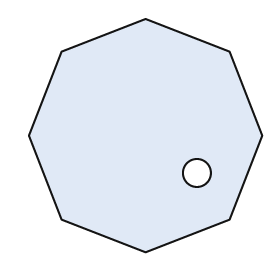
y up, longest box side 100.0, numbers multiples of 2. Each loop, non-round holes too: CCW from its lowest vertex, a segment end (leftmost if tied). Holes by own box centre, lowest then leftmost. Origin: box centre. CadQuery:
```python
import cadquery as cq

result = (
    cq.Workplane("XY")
    .moveTo(0.0, -50.0)
    .lineTo(36.0, -36.0)
    .lineTo(50.0, 0.0)
    .lineTo(36.0, 36.0)
    .lineTo(0.0, 50.0)
    .lineTo(-36.0, 36.0)
    .lineTo(-50.0, 0.0)
    .lineTo(-36.0, -36.0)
    .close()
    .moveTo(22.0, -16.0)
    .circle(6.0)
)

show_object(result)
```